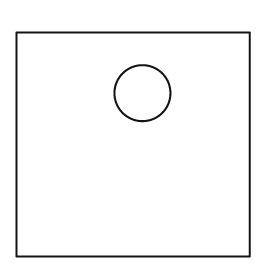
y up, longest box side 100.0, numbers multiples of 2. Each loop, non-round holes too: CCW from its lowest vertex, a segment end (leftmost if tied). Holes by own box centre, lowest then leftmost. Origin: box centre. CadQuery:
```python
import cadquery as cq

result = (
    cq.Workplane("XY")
    .moveTo(-50.0, -48.0)
    .lineTo(50.0, -48.0)
    .lineTo(50.0, 48.0)
    .lineTo(-50.0, 48.0)
    .close()
    .moveTo(4.0, 22.0)
    .circle(12.0)
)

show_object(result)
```